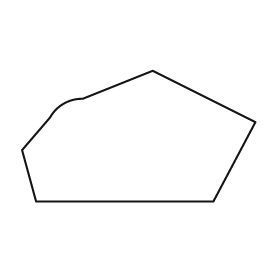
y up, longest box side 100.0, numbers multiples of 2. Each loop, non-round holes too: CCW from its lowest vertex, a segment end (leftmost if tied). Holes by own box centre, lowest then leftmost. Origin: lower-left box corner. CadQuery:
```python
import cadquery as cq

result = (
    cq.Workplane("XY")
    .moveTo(6.0, 0.0)
    .lineTo(82.0, 0.0)
    .lineTo(100.0, 34.0)
    .lineTo(56.0, 56.0)
    .lineTo(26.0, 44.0)
    .threePointArc((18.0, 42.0), (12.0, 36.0))
    .lineTo(0.0, 22.0)
    .close()
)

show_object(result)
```